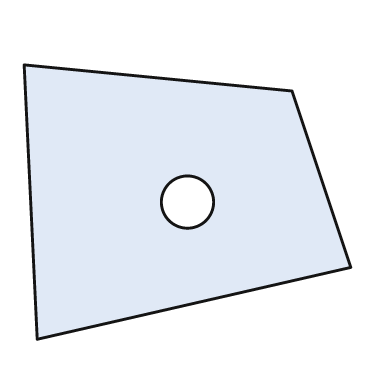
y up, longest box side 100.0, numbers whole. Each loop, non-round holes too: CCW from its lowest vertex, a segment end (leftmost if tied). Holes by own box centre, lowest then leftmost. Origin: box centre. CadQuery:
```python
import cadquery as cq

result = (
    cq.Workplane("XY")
    .moveTo(-46.0, -42.0)
    .lineTo(50.0, -20.0)
    .lineTo(32.0, 34.0)
    .lineTo(-50.0, 42.0)
    .close()
    .moveTo(0.0, 0.0)
    .circle(8.0)
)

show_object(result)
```